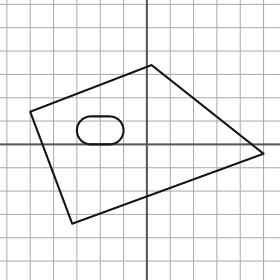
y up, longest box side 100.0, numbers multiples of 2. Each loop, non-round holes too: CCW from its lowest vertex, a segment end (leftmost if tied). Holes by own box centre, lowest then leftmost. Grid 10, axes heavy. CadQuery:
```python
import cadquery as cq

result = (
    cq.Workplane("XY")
    .moveTo(-32.0, -34.0)
    .lineTo(50.0, -4.0)
    .lineTo(2.0, 34.0)
    .lineTo(-50.0, 14.0)
    .close()
    .moveTo(-24.0, 0.0)
    .lineTo(-16.0, 0.0)
    .threePointArc((-10.0, 6.0), (-16.0, 12.0))
    .lineTo(-24.0, 12.0)
    .threePointArc((-30.0, 6.0), (-24.0, 0.0))
    .close()
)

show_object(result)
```